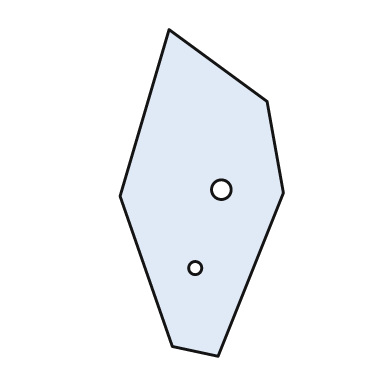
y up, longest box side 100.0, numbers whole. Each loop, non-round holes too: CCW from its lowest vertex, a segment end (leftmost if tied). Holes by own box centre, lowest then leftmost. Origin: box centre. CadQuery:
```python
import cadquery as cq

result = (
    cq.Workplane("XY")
    .moveTo(5.0, -50.0)
    .lineTo(25.0, 0.0)
    .lineTo(20.0, 28.0)
    .lineTo(-10.0, 50.0)
    .lineTo(-25.0, -1.0)
    .lineTo(-9.0, -47.0)
    .close()
    .moveTo(-2.0, -23.0)
    .circle(2.0)
    .moveTo(6.0, 1.0)
    .circle(3.0)
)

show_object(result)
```